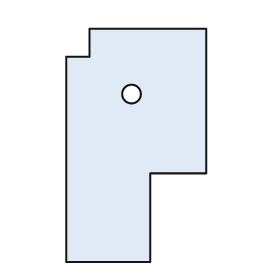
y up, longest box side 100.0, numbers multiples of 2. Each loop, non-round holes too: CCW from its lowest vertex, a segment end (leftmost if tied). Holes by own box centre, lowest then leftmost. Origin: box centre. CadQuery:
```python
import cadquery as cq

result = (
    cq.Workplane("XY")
    .moveTo(-30.0, -50.0)
    .lineTo(6.0, -50.0)
    .lineTo(6.0, -12.0)
    .lineTo(30.0, -12.0)
    .lineTo(30.0, 50.0)
    .lineTo(-20.0, 50.0)
    .lineTo(-20.0, 38.0)
    .lineTo(-30.0, 38.0)
    .close()
    .moveTo(-2.0, 22.0)
    .circle(4.0)
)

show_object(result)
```